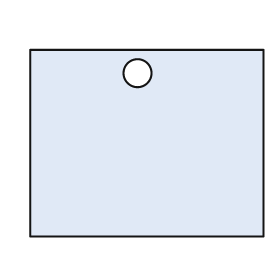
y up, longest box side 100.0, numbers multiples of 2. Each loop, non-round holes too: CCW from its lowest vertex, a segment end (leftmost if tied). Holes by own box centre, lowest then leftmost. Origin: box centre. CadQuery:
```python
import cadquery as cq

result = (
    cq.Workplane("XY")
    .moveTo(-50.0, -40.0)
    .lineTo(50.0, -40.0)
    .lineTo(50.0, 40.0)
    .lineTo(-50.0, 40.0)
    .close()
    .moveTo(-4.0, 30.0)
    .circle(6.0)
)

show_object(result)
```